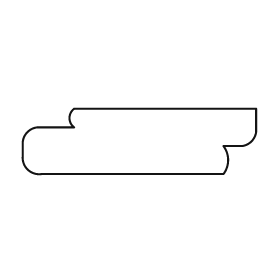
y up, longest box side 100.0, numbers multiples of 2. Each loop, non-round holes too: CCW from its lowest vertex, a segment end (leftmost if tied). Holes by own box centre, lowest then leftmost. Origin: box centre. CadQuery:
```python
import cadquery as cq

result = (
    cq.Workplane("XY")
    .moveTo(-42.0, -14.0)
    .lineTo(36.0, -14.0)
    .threePointArc((38.0, -8.0), (36.0, -2.0))
    .lineTo(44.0, -2.0)
    .threePointArc((48.0, 0.0), (50.0, 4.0))
    .lineTo(50.0, 14.0)
    .lineTo(-28.0, 14.0)
    .threePointArc((-30.0, 10.0), (-28.0, 6.0))
    .lineTo(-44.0, 6.0)
    .threePointArc((-48.0, 4.0), (-50.0, 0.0))
    .lineTo(-50.0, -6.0)
    .threePointArc((-48.0, -12.0), (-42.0, -14.0))
    .close()
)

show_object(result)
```